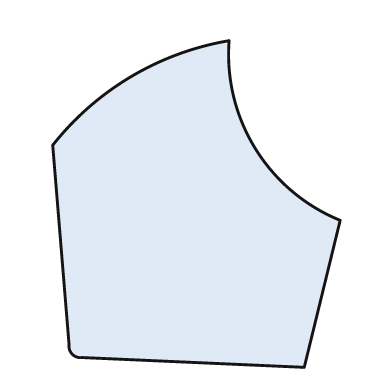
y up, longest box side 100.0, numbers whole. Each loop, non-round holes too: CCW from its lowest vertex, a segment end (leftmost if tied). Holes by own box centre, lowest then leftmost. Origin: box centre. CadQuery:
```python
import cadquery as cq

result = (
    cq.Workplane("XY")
    .moveTo(33.0, -50.0)
    .lineTo(44.0, -5.0)
    .threePointArc((18.0, 17.0), (10.0, 50.0))
    .threePointArc((-20.0, 39.0), (-44.0, 18.0))
    .lineTo(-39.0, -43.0)
    .threePointArc((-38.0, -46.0), (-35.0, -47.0))
    .close()
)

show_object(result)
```